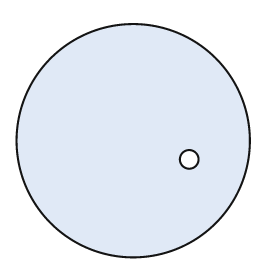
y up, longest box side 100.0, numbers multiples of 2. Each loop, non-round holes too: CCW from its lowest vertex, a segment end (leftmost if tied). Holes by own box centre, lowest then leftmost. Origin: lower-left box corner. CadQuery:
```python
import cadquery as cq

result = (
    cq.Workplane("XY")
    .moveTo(50.0, 50.0)
    .circle(50.0)
    .moveTo(74.0, 42.0)
    .circle(4.0)
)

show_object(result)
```